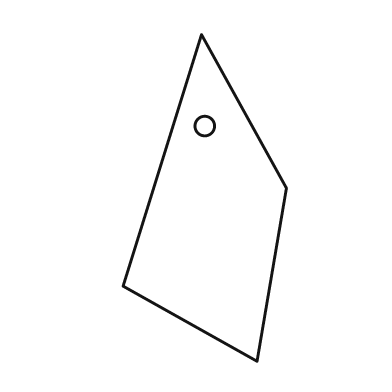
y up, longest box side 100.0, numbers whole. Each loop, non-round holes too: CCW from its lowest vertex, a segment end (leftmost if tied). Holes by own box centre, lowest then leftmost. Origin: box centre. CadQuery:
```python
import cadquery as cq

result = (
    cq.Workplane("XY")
    .moveTo(16.0, -50.0)
    .lineTo(25.0, 3.0)
    .lineTo(-1.0, 50.0)
    .lineTo(-25.0, -27.0)
    .close()
    .moveTo(0.0, 22.0)
    .circle(3.0)
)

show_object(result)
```